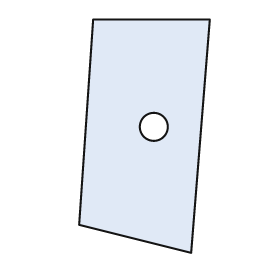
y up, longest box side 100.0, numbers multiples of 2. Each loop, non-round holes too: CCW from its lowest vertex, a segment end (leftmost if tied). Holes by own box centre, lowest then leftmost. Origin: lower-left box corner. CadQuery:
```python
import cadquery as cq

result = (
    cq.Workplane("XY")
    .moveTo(48.0, 0.0)
    .lineTo(56.0, 100.0)
    .lineTo(6.0, 100.0)
    .lineTo(0.0, 12.0)
    .close()
    .moveTo(32.0, 54.0)
    .circle(6.0)
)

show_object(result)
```